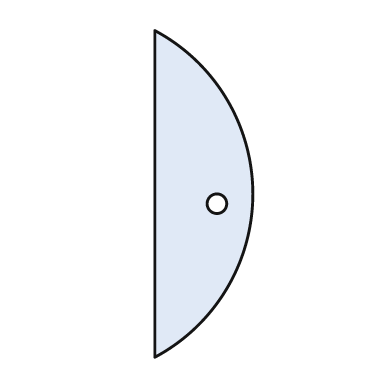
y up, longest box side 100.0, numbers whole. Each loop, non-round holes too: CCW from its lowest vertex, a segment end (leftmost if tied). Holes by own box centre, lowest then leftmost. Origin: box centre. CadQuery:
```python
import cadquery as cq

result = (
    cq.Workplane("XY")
    .moveTo(-15.0, -50.0)
    .threePointArc((15.0, 0.0), (-15.0, 50.0))
    .close()
    .moveTo(4.0, -3.0)
    .circle(3.0)
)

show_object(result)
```